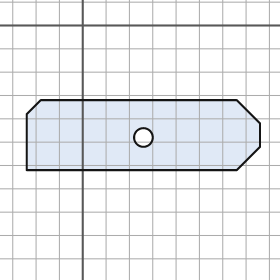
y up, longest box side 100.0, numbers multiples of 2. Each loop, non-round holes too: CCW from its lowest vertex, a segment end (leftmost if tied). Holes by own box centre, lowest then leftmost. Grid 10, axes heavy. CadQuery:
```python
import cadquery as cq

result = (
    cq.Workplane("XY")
    .moveTo(-24.0, -62.0)
    .lineTo(66.0, -62.0)
    .lineTo(76.0, -52.0)
    .lineTo(76.0, -42.0)
    .lineTo(66.0, -32.0)
    .lineTo(-18.0, -32.0)
    .lineTo(-24.0, -38.0)
    .close()
    .moveTo(26.0, -48.0)
    .circle(4.0)
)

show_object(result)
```